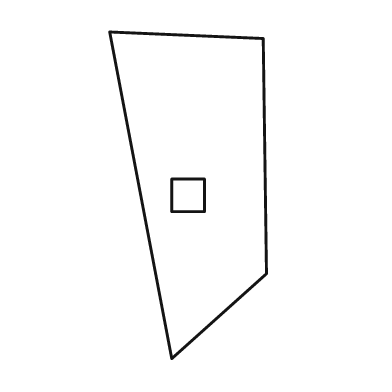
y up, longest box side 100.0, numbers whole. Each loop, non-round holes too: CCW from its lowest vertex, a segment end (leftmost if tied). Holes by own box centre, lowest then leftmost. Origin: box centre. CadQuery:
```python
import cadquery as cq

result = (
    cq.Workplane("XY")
    .moveTo(-5.0, -50.0)
    .lineTo(24.0, -24.0)
    .lineTo(23.0, 48.0)
    .lineTo(-24.0, 50.0)
    .close()
    .moveTo(-5.0, -5.0)
    .lineTo(5.0, -5.0)
    .lineTo(5.0, 5.0)
    .lineTo(-5.0, 5.0)
    .close()
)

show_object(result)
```